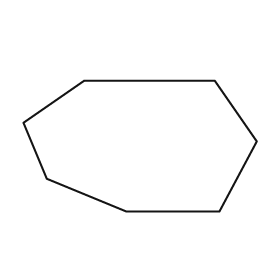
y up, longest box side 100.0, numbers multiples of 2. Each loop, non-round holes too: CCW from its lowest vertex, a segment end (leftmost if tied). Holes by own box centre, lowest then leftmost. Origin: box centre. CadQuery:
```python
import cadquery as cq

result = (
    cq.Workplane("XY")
    .moveTo(-6.0, -28.0)
    .lineTo(34.0, -28.0)
    .lineTo(50.0, 2.0)
    .lineTo(32.0, 28.0)
    .lineTo(-24.0, 28.0)
    .lineTo(-50.0, 10.0)
    .lineTo(-40.0, -14.0)
    .close()
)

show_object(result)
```